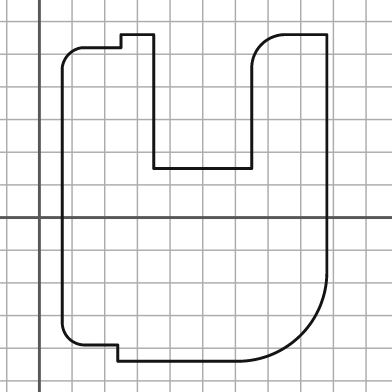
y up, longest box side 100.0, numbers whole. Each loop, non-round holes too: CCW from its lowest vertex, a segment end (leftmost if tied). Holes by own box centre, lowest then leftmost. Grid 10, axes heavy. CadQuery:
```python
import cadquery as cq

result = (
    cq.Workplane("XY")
    .moveTo(24.0, -44.0)
    .lineTo(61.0, -44.0)
    .threePointArc((80.0, -36.0), (88.0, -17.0))
    .lineTo(88.0, 56.0)
    .lineTo(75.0, 56.0)
    .threePointArc((68.0, 53.0), (65.0, 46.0))
    .lineTo(65.0, 15.0)
    .lineTo(35.0, 15.0)
    .lineTo(35.0, 56.0)
    .lineTo(25.0, 56.0)
    .lineTo(25.0, 52.0)
    .lineTo(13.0, 52.0)
    .threePointArc((9.0, 50.0), (7.0, 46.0))
    .lineTo(7.0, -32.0)
    .threePointArc((9.0, -37.0), (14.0, -39.0))
    .lineTo(24.0, -39.0)
    .close()
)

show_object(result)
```